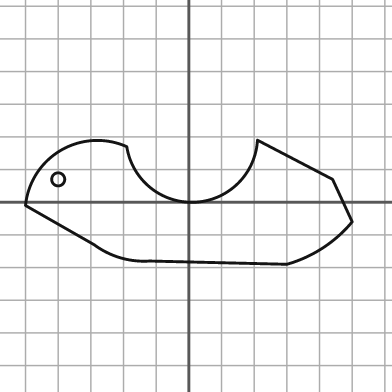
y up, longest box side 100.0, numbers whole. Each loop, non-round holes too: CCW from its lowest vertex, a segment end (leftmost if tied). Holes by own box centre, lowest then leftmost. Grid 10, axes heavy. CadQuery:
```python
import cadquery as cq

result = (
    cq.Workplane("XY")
    .moveTo(30.0, -19.0)
    .threePointArc((41.0, -14.0), (50.0, -6.0))
    .lineTo(44.0, 7.0)
    .lineTo(21.0, 19.0)
    .threePointArc((2.0, 0.0), (-19.0, 17.0))
    .threePointArc((-39.0, 16.0), (-50.0, -1.0))
    .lineTo(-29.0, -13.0)
    .threePointArc((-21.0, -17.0), (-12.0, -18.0))
    .close()
    .moveTo(-40.0, 7.0)
    .circle(2.0)
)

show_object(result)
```